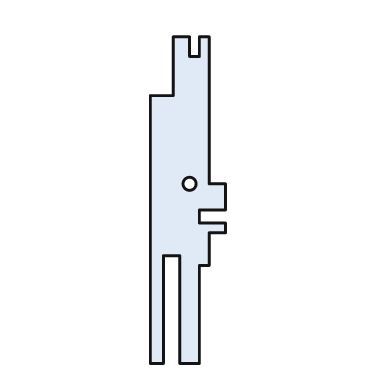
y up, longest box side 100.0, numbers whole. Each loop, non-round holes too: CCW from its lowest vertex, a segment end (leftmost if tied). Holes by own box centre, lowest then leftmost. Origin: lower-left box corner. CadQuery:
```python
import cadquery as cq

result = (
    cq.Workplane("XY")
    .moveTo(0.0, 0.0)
    .lineTo(4.0, 0.0)
    .lineTo(4.0, 33.0)
    .lineTo(9.0, 33.0)
    .lineTo(9.0, 0.0)
    .lineTo(15.0, 0.0)
    .lineTo(15.0, 30.0)
    .lineTo(18.0, 30.0)
    .lineTo(18.0, 40.0)
    .lineTo(23.0, 40.0)
    .lineTo(23.0, 43.0)
    .lineTo(15.0, 43.0)
    .lineTo(15.0, 47.0)
    .lineTo(23.0, 47.0)
    .lineTo(23.0, 55.0)
    .lineTo(18.0, 55.0)
    .lineTo(18.0, 100.0)
    .lineTo(15.0, 100.0)
    .lineTo(15.0, 94.0)
    .lineTo(12.0, 94.0)
    .lineTo(12.0, 100.0)
    .lineTo(7.0, 100.0)
    .lineTo(7.0, 82.0)
    .lineTo(0.0, 82.0)
    .close()
    .moveTo(12.0, 55.0)
    .circle(2.0)
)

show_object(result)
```